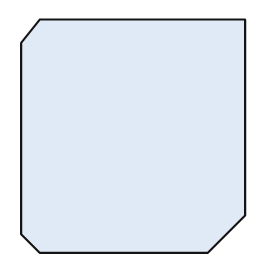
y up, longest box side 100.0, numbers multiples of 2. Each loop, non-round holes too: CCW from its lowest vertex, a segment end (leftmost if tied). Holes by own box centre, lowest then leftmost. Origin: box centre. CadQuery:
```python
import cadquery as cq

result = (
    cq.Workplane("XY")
    .moveTo(-40.0, -50.0)
    .lineTo(32.0, -50.0)
    .lineTo(48.0, -34.0)
    .lineTo(48.0, 50.0)
    .lineTo(-40.0, 50.0)
    .lineTo(-48.0, 40.0)
    .lineTo(-48.0, -42.0)
    .close()
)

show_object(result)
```